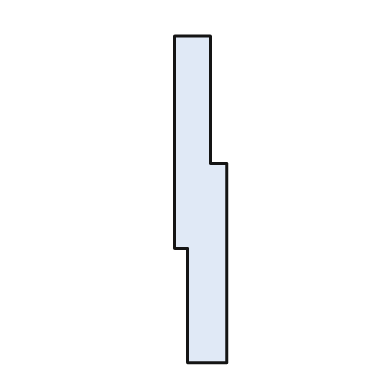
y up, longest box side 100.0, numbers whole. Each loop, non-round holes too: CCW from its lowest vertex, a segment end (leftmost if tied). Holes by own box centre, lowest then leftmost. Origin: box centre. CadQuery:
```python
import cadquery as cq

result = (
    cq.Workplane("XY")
    .moveTo(-4.0, -50.0)
    .lineTo(8.0, -50.0)
    .lineTo(8.0, 11.0)
    .lineTo(3.0, 11.0)
    .lineTo(3.0, 50.0)
    .lineTo(-8.0, 50.0)
    .lineTo(-8.0, -15.0)
    .lineTo(-4.0, -15.0)
    .close()
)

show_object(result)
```